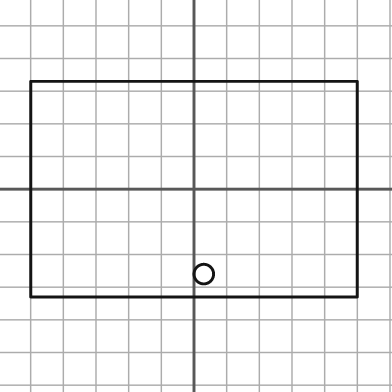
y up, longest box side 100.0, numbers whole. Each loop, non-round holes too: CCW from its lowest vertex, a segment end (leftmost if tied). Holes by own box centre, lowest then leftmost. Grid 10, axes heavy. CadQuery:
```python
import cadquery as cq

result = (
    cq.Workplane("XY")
    .moveTo(-50.0, -33.0)
    .lineTo(50.0, -33.0)
    .lineTo(50.0, 33.0)
    .lineTo(-50.0, 33.0)
    .close()
    .moveTo(3.0, -26.0)
    .circle(3.0)
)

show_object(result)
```